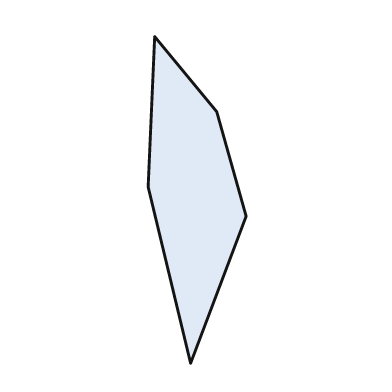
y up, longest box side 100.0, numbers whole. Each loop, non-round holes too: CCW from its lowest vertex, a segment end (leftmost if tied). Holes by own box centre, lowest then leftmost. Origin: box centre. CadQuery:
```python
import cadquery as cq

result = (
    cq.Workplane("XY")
    .moveTo(-2.0, -50.0)
    .lineTo(15.0, -5.0)
    .lineTo(6.0, 27.0)
    .lineTo(-13.0, 50.0)
    .lineTo(-15.0, 4.0)
    .close()
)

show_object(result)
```